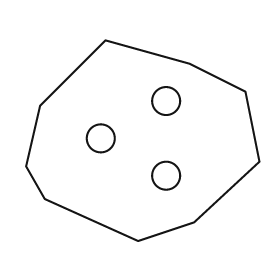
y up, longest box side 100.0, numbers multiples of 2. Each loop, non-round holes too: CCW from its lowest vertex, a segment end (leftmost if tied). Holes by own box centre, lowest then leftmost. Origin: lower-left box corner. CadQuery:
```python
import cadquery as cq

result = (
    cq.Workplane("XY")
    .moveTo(48.0, 0.0)
    .lineTo(72.0, 8.0)
    .lineTo(100.0, 34.0)
    .lineTo(94.0, 64.0)
    .lineTo(70.0, 76.0)
    .lineTo(34.0, 86.0)
    .lineTo(6.0, 58.0)
    .lineTo(0.0, 32.0)
    .lineTo(8.0, 18.0)
    .close()
    .moveTo(60.0, 28.0)
    .circle(6.0)
    .moveTo(32.0, 44.0)
    .circle(6.0)
    .moveTo(60.0, 60.0)
    .circle(6.0)
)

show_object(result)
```